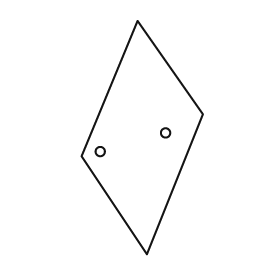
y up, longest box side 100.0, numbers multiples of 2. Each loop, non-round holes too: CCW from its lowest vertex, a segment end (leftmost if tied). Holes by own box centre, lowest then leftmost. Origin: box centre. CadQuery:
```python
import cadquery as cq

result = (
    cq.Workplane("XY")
    .moveTo(2.0, -50.0)
    .lineTo(26.0, 10.0)
    .lineTo(-2.0, 50.0)
    .lineTo(-26.0, -8.0)
    .close()
    .moveTo(-18.0, -6.0)
    .circle(2.0)
    .moveTo(10.0, 2.0)
    .circle(2.0)
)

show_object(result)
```